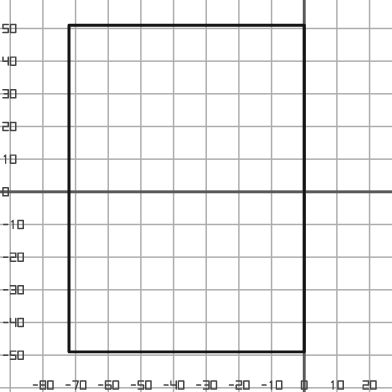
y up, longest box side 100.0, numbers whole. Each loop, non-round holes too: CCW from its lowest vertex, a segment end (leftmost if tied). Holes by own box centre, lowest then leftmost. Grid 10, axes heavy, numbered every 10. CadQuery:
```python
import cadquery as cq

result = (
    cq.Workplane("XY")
    .moveTo(-72.0, -49.0)
    .lineTo(0.0, -49.0)
    .lineTo(0.0, 51.0)
    .lineTo(-72.0, 51.0)
    .close()
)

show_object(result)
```